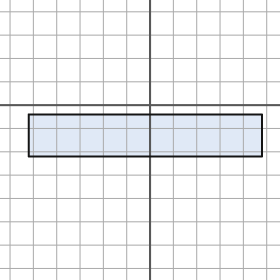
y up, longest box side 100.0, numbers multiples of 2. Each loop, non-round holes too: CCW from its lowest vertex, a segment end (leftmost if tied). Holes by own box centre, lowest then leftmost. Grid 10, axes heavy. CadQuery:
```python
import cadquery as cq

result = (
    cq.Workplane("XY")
    .moveTo(-52.0, -22.0)
    .lineTo(48.0, -22.0)
    .lineTo(48.0, -4.0)
    .lineTo(-52.0, -4.0)
    .close()
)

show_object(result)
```